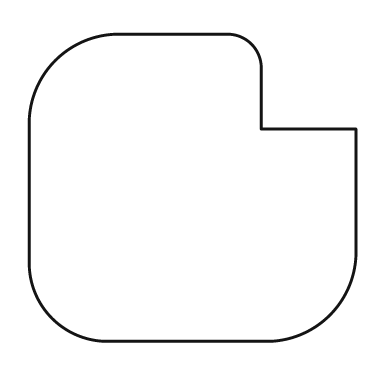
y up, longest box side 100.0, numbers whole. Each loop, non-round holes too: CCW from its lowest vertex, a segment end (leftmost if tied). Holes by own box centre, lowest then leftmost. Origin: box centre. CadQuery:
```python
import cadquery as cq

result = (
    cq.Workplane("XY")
    .moveTo(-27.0, -47.0)
    .lineTo(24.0, -47.0)
    .threePointArc((42.0, -39.0), (50.0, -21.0))
    .lineTo(50.0, 18.0)
    .lineTo(21.0, 18.0)
    .lineTo(21.0, 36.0)
    .threePointArc((18.0, 44.0), (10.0, 47.0))
    .lineTo(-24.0, 47.0)
    .threePointArc((-42.0, 39.0), (-50.0, 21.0))
    .lineTo(-50.0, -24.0)
    .threePointArc((-43.0, -40.0), (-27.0, -47.0))
    .close()
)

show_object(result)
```